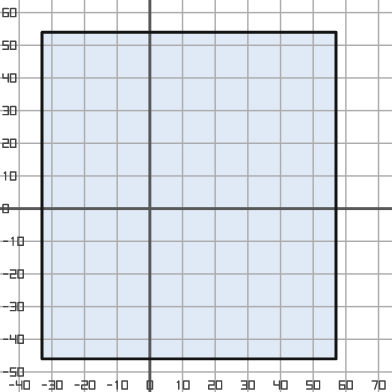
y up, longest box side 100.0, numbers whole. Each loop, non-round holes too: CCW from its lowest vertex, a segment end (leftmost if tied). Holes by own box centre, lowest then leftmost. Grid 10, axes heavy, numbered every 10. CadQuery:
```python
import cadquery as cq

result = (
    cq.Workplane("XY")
    .moveTo(-33.0, -46.0)
    .lineTo(57.0, -46.0)
    .lineTo(57.0, 54.0)
    .lineTo(-33.0, 54.0)
    .close()
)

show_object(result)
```